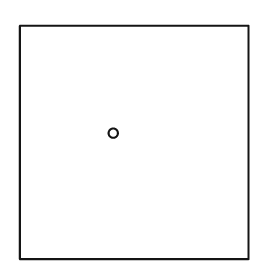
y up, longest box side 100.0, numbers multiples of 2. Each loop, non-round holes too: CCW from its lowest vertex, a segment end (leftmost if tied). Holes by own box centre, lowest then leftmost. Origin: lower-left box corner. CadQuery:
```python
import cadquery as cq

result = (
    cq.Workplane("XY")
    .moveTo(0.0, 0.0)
    .lineTo(98.0, 0.0)
    .lineTo(98.0, 100.0)
    .lineTo(0.0, 100.0)
    .close()
    .moveTo(40.0, 54.0)
    .circle(2.0)
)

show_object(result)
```